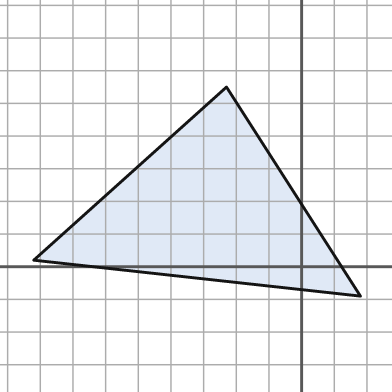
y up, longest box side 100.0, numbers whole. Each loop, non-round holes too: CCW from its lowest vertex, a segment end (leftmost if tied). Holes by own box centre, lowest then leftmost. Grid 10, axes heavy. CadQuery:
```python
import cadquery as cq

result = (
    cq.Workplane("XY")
    .moveTo(18.0, -9.0)
    .lineTo(-23.0, 55.0)
    .lineTo(-82.0, 2.0)
    .close()
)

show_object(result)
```